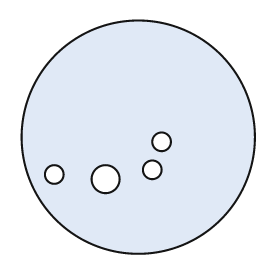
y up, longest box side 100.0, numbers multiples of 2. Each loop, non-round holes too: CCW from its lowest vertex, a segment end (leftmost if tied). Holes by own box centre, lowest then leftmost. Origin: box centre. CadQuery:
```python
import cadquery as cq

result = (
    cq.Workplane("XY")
    .moveTo(0.0, 0.0)
    .circle(50.0)
    .moveTo(-14.0, -18.0)
    .circle(6.0)
    .moveTo(-36.0, -16.0)
    .circle(4.0)
    .moveTo(6.0, -14.0)
    .circle(4.0)
    .moveTo(10.0, -2.0)
    .circle(4.0)
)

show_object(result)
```